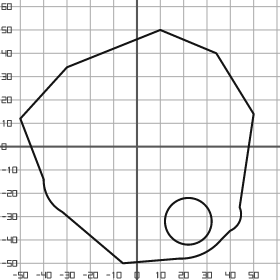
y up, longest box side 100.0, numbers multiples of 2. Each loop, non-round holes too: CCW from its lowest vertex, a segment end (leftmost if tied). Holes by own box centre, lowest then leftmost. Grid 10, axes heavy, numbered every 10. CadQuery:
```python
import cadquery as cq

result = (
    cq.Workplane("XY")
    .moveTo(-6.0, -50.0)
    .lineTo(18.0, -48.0)
    .threePointArc((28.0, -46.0), (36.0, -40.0))
    .lineTo(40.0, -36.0)
    .threePointArc((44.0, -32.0), (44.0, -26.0))
    .lineTo(50.0, 14.0)
    .lineTo(34.0, 40.0)
    .lineTo(10.0, 50.0)
    .lineTo(-30.0, 34.0)
    .lineTo(-50.0, 12.0)
    .lineTo(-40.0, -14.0)
    .threePointArc((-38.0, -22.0), (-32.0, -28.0))
    .close()
    .moveTo(22.0, -32.0)
    .circle(10.0)
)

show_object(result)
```